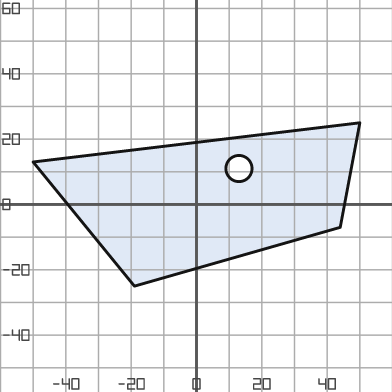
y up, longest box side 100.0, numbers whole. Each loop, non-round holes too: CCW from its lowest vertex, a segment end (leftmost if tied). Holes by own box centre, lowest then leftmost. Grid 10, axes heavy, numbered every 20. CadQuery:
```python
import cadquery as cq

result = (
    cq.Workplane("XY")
    .moveTo(-19.0, -25.0)
    .lineTo(44.0, -7.0)
    .lineTo(50.0, 25.0)
    .lineTo(-50.0, 13.0)
    .close()
    .moveTo(13.0, 11.0)
    .circle(4.0)
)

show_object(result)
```